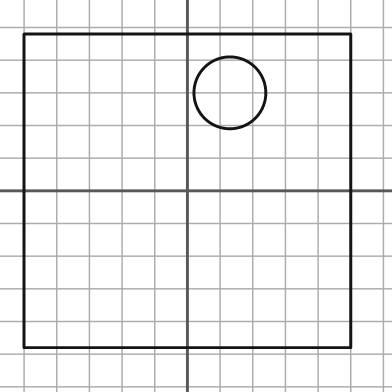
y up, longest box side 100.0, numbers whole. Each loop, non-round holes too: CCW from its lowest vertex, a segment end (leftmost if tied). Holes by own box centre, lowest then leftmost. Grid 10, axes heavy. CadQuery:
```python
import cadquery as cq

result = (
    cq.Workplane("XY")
    .moveTo(-50.0, -48.0)
    .lineTo(50.0, -48.0)
    .lineTo(50.0, 48.0)
    .lineTo(-50.0, 48.0)
    .close()
    .moveTo(13.0, 30.0)
    .circle(11.0)
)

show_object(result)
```